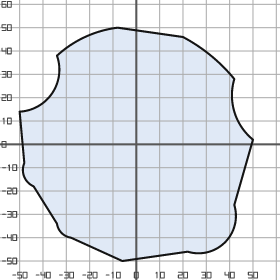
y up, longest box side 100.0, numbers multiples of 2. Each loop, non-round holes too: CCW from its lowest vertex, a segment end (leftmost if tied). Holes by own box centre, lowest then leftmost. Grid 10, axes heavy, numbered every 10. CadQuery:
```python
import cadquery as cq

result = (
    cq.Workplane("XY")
    .moveTo(-6.0, -50.0)
    .lineTo(22.0, -46.0)
    .threePointArc((38.0, -42.0), (42.0, -26.0))
    .lineTo(50.0, 2.0)
    .threePointArc((42.0, 14.0), (42.0, 28.0))
    .threePointArc((32.0, 38.0), (20.0, 46.0))
    .lineTo(-8.0, 50.0)
    .threePointArc((-22.0, 46.0), (-34.0, 38.0))
    .threePointArc((-36.0, 22.0), (-50.0, 14.0))
    .lineTo(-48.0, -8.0)
    .threePointArc((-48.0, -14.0), (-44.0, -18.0))
    .lineTo(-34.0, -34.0)
    .threePointArc((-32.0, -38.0), (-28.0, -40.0))
    .close()
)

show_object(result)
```